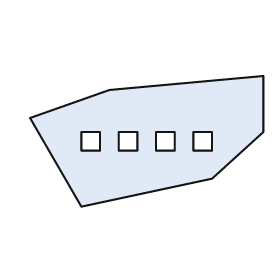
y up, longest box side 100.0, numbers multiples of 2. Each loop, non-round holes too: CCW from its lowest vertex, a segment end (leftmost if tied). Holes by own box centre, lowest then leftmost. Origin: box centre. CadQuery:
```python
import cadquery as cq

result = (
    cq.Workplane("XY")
    .moveTo(-28.0, -28.0)
    .lineTo(28.0, -16.0)
    .lineTo(50.0, 4.0)
    .lineTo(50.0, 28.0)
    .lineTo(-16.0, 22.0)
    .lineTo(-50.0, 10.0)
    .close()
    .moveTo(-28.0, -4.0)
    .lineTo(-20.0, -4.0)
    .lineTo(-20.0, 4.0)
    .lineTo(-28.0, 4.0)
    .close()
    .moveTo(-12.0, -4.0)
    .lineTo(-4.0, -4.0)
    .lineTo(-4.0, 4.0)
    .lineTo(-12.0, 4.0)
    .close()
    .moveTo(4.0, -4.0)
    .lineTo(12.0, -4.0)
    .lineTo(12.0, 4.0)
    .lineTo(4.0, 4.0)
    .close()
    .moveTo(20.0, -4.0)
    .lineTo(28.0, -4.0)
    .lineTo(28.0, 4.0)
    .lineTo(20.0, 4.0)
    .close()
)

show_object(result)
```